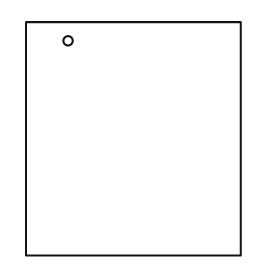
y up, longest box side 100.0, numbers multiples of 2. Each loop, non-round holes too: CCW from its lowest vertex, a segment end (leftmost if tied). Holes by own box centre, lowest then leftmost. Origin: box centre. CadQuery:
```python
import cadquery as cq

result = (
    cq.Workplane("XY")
    .moveTo(-46.0, -50.0)
    .lineTo(46.0, -50.0)
    .lineTo(46.0, 50.0)
    .lineTo(-46.0, 50.0)
    .close()
    .moveTo(-28.0, 42.0)
    .circle(2.0)
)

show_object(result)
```